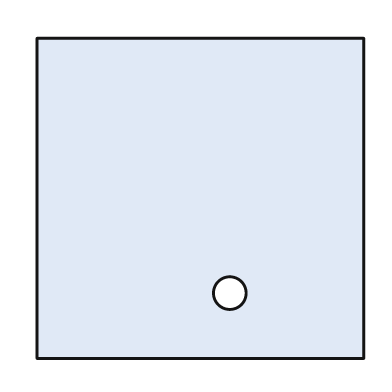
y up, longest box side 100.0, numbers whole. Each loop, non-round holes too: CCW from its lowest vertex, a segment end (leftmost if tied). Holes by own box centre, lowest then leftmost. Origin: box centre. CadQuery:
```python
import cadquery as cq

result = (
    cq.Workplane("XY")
    .moveTo(-50.0, -49.0)
    .lineTo(50.0, -49.0)
    .lineTo(50.0, 49.0)
    .lineTo(-50.0, 49.0)
    .close()
    .moveTo(9.0, -29.0)
    .circle(5.0)
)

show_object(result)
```